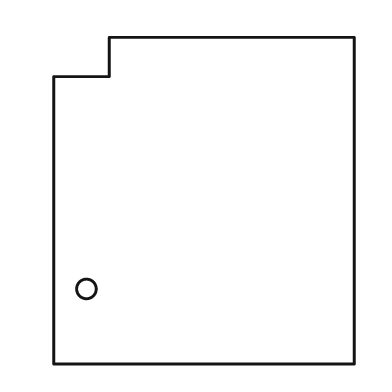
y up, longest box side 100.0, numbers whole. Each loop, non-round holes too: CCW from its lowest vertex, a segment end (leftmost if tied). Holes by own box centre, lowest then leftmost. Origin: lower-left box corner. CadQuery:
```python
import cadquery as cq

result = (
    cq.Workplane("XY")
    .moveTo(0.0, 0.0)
    .lineTo(92.0, 0.0)
    .lineTo(92.0, 100.0)
    .lineTo(17.0, 100.0)
    .lineTo(17.0, 88.0)
    .lineTo(0.0, 88.0)
    .close()
    .moveTo(10.0, 23.0)
    .circle(3.0)
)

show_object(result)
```